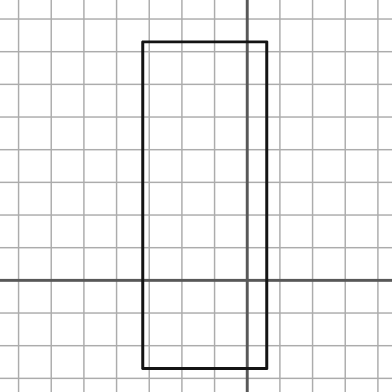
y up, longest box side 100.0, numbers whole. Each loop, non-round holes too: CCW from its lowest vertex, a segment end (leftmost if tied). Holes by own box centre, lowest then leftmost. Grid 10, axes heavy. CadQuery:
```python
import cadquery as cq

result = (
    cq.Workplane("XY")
    .moveTo(-32.0, -27.0)
    .lineTo(6.0, -27.0)
    .lineTo(6.0, 73.0)
    .lineTo(-32.0, 73.0)
    .close()
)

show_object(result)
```